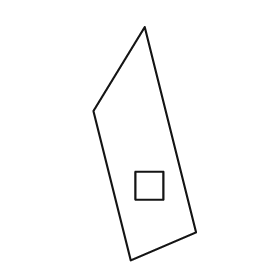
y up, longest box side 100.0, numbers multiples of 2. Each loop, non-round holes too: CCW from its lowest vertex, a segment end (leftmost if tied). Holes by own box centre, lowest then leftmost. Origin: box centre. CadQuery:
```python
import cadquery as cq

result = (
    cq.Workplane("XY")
    .moveTo(-6.0, -50.0)
    .lineTo(22.0, -38.0)
    .lineTo(0.0, 50.0)
    .lineTo(-22.0, 14.0)
    .close()
    .moveTo(-4.0, -24.0)
    .lineTo(8.0, -24.0)
    .lineTo(8.0, -12.0)
    .lineTo(-4.0, -12.0)
    .close()
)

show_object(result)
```